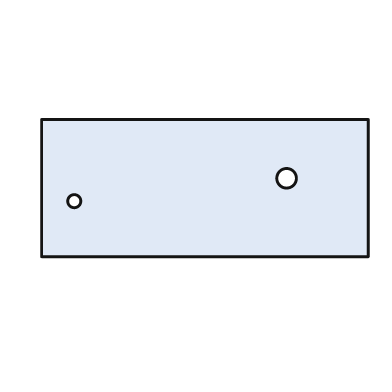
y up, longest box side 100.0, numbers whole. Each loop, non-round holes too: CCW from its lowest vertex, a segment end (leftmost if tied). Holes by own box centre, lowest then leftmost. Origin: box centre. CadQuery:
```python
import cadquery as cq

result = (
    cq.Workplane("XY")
    .moveTo(-50.0, -21.0)
    .lineTo(50.0, -21.0)
    .lineTo(50.0, 21.0)
    .lineTo(-50.0, 21.0)
    .close()
    .moveTo(-40.0, -4.0)
    .circle(2.0)
    .moveTo(25.0, 3.0)
    .circle(3.0)
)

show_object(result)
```